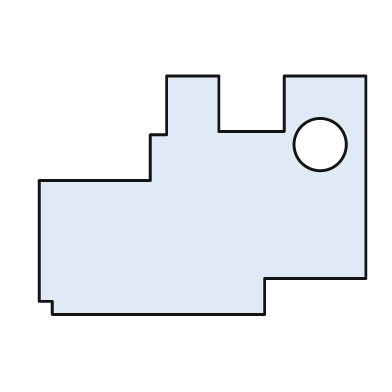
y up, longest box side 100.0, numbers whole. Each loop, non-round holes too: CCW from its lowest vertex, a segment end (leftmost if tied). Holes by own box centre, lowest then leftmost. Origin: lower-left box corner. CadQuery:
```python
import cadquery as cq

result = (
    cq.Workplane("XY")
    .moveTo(4.0, 0.0)
    .lineTo(69.0, 0.0)
    .lineTo(69.0, 11.0)
    .lineTo(100.0, 11.0)
    .lineTo(100.0, 73.0)
    .lineTo(75.0, 73.0)
    .lineTo(75.0, 56.0)
    .lineTo(55.0, 56.0)
    .lineTo(55.0, 73.0)
    .lineTo(39.0, 73.0)
    .lineTo(39.0, 55.0)
    .lineTo(34.0, 55.0)
    .lineTo(34.0, 41.0)
    .lineTo(0.0, 41.0)
    .lineTo(0.0, 4.0)
    .lineTo(4.0, 4.0)
    .close()
    .moveTo(86.0, 52.0)
    .circle(8.0)
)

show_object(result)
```